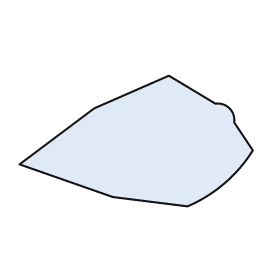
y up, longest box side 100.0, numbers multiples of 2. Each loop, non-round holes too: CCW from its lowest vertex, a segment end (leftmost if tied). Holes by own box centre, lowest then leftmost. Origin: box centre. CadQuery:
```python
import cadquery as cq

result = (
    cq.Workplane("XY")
    .moveTo(22.0, -28.0)
    .threePointArc((38.0, -18.0), (50.0, -4.0))
    .lineTo(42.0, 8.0)
    .threePointArc((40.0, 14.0), (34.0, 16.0))
    .lineTo(14.0, 28.0)
    .lineTo(-18.0, 14.0)
    .lineTo(-50.0, -10.0)
    .lineTo(-10.0, -24.0)
    .close()
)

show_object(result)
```